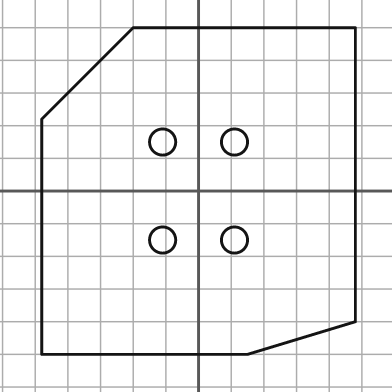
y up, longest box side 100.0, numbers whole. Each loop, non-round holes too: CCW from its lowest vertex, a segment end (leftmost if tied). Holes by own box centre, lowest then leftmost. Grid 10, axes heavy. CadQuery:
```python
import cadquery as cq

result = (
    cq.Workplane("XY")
    .moveTo(-48.0, -50.0)
    .lineTo(15.0, -50.0)
    .lineTo(48.0, -40.0)
    .lineTo(48.0, 50.0)
    .lineTo(-20.0, 50.0)
    .lineTo(-48.0, 22.0)
    .close()
    .moveTo(-11.0, -15.0)
    .circle(4.0)
    .moveTo(11.0, -15.0)
    .circle(4.0)
    .moveTo(-11.0, 15.0)
    .circle(4.0)
    .moveTo(11.0, 15.0)
    .circle(4.0)
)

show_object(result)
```